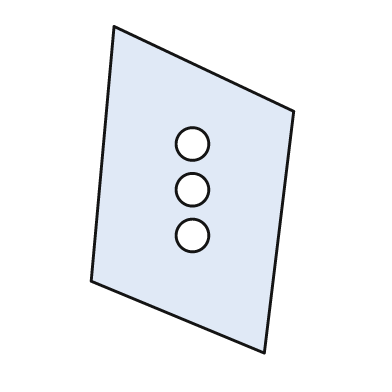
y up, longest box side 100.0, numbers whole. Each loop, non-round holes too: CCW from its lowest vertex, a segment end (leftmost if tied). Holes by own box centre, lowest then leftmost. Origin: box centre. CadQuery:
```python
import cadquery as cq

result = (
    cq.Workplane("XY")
    .moveTo(22.0, -50.0)
    .lineTo(31.0, 24.0)
    .lineTo(-24.0, 50.0)
    .lineTo(-31.0, -28.0)
    .close()
    .moveTo(0.0, -14.0)
    .circle(5.0)
    .moveTo(0.0, 0.0)
    .circle(5.0)
    .moveTo(0.0, 14.0)
    .circle(5.0)
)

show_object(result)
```